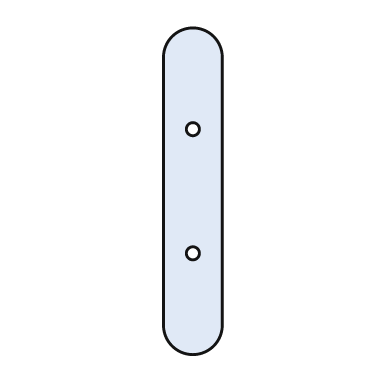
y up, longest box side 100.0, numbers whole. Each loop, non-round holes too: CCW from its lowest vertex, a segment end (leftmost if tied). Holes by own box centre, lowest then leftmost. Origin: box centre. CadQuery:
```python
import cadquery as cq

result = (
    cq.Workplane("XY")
    .moveTo(-9.0, -41.0)
    .threePointArc((0.0, -50.0), (9.0, -41.0))
    .lineTo(9.0, 41.0)
    .threePointArc((0.0, 50.0), (-9.0, 41.0))
    .close()
    .moveTo(0.0, -19.0)
    .circle(2.0)
    .moveTo(0.0, 19.0)
    .circle(2.0)
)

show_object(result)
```